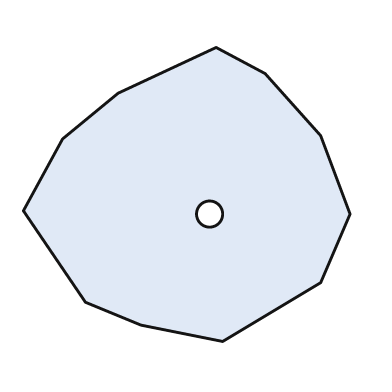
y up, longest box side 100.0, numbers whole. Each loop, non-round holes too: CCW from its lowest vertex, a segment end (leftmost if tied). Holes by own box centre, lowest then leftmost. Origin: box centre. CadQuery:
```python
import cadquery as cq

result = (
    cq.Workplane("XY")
    .moveTo(11.0, -45.0)
    .lineTo(41.0, -27.0)
    .lineTo(50.0, -6.0)
    .lineTo(41.0, 18.0)
    .lineTo(24.0, 37.0)
    .lineTo(9.0, 45.0)
    .lineTo(-21.0, 31.0)
    .lineTo(-38.0, 17.0)
    .lineTo(-50.0, -5.0)
    .lineTo(-31.0, -33.0)
    .lineTo(-14.0, -40.0)
    .close()
    .moveTo(7.0, -6.0)
    .circle(4.0)
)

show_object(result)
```